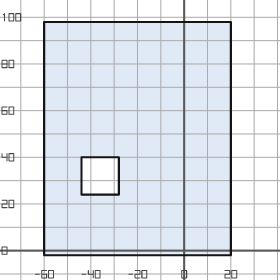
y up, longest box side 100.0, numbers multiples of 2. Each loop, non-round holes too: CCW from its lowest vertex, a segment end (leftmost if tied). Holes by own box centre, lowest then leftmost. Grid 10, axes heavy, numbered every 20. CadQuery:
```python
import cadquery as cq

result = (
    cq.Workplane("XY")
    .moveTo(-60.0, -2.0)
    .lineTo(20.0, -2.0)
    .lineTo(20.0, 98.0)
    .lineTo(-60.0, 98.0)
    .close()
    .moveTo(-44.0, 24.0)
    .lineTo(-28.0, 24.0)
    .lineTo(-28.0, 40.0)
    .lineTo(-44.0, 40.0)
    .close()
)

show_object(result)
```